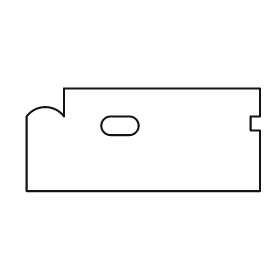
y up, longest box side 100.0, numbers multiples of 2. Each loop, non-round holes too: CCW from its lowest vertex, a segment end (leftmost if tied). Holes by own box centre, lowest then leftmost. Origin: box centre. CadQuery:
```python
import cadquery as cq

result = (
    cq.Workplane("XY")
    .moveTo(-50.0, -22.0)
    .lineTo(50.0, -22.0)
    .lineTo(50.0, 4.0)
    .lineTo(46.0, 4.0)
    .lineTo(46.0, 10.0)
    .lineTo(50.0, 10.0)
    .lineTo(50.0, 22.0)
    .lineTo(-34.0, 22.0)
    .lineTo(-34.0, 10.0)
    .threePointArc((-42.0, 14.0), (-50.0, 10.0))
    .close()
    .moveTo(-14.0, 2.0)
    .lineTo(-6.0, 2.0)
    .threePointArc((-2.0, 6.0), (-6.0, 10.0))
    .lineTo(-14.0, 10.0)
    .threePointArc((-18.0, 6.0), (-14.0, 2.0))
    .close()
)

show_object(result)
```